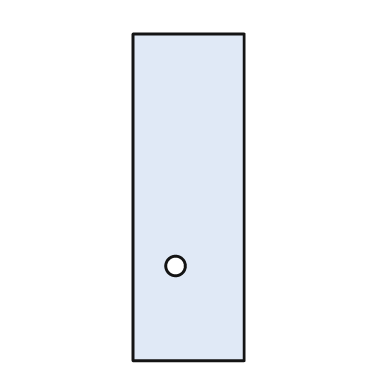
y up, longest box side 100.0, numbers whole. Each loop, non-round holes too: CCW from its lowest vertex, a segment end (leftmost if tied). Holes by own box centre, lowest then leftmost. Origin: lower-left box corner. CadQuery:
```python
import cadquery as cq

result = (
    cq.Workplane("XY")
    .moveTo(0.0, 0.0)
    .lineTo(34.0, 0.0)
    .lineTo(34.0, 100.0)
    .lineTo(0.0, 100.0)
    .close()
    .moveTo(13.0, 29.0)
    .circle(3.0)
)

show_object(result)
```